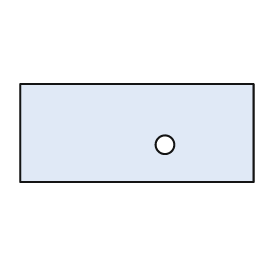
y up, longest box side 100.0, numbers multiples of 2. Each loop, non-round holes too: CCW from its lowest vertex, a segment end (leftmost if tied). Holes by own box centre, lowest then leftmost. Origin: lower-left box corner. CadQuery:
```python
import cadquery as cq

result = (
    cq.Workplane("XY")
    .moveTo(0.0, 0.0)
    .lineTo(100.0, 0.0)
    .lineTo(100.0, 42.0)
    .lineTo(0.0, 42.0)
    .close()
    .moveTo(62.0, 16.0)
    .circle(4.0)
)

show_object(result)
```